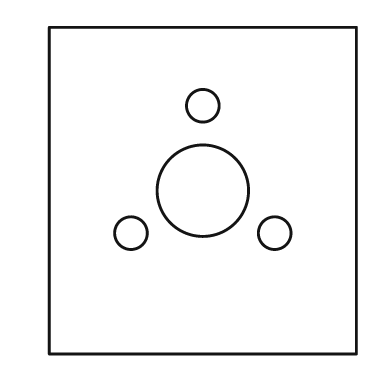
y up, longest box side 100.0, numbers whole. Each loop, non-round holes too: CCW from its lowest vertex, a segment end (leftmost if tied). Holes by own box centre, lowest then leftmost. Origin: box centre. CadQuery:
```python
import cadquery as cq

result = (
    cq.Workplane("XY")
    .moveTo(-47.0, -50.0)
    .lineTo(47.0, -50.0)
    .lineTo(47.0, 50.0)
    .lineTo(-47.0, 50.0)
    .close()
    .moveTo(-22.0, -13.0)
    .circle(5.0)
    .moveTo(22.0, -13.0)
    .circle(5.0)
    .moveTo(0.0, 0.0)
    .circle(14.0)
    .moveTo(0.0, 26.0)
    .circle(5.0)
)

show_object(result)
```